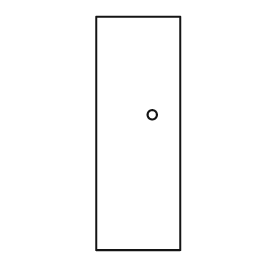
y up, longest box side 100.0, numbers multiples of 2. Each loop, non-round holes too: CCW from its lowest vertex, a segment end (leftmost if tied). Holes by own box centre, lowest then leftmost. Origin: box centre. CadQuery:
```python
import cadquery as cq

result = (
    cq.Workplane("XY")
    .moveTo(-18.0, -50.0)
    .lineTo(18.0, -50.0)
    .lineTo(18.0, 50.0)
    .lineTo(-18.0, 50.0)
    .close()
    .moveTo(6.0, 8.0)
    .circle(2.0)
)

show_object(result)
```